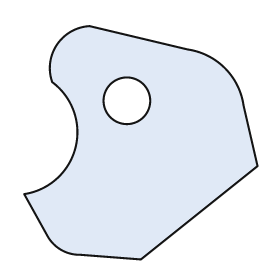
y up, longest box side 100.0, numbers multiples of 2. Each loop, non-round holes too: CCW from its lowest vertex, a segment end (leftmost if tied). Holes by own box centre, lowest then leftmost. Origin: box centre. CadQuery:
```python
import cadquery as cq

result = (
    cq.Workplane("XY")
    .moveTo(0.0, -50.0)
    .lineTo(50.0, -10.0)
    .lineTo(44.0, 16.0)
    .threePointArc((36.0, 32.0), (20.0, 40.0))
    .lineTo(-22.0, 50.0)
    .threePointArc((-36.0, 42.0), (-38.0, 26.0))
    .threePointArc((-28.0, -2.0), (-50.0, -22.0))
    .lineTo(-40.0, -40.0)
    .threePointArc((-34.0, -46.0), (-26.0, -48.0))
    .close()
    .moveTo(-6.0, 18.0)
    .circle(10.0)
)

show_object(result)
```